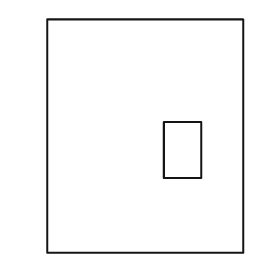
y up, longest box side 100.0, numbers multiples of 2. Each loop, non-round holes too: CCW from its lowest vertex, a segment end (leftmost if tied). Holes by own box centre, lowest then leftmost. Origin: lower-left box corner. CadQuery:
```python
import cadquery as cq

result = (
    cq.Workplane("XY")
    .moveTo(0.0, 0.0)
    .lineTo(84.0, 0.0)
    .lineTo(84.0, 100.0)
    .lineTo(0.0, 100.0)
    .close()
    .moveTo(50.0, 32.0)
    .lineTo(66.0, 32.0)
    .lineTo(66.0, 56.0)
    .lineTo(50.0, 56.0)
    .close()
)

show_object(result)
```